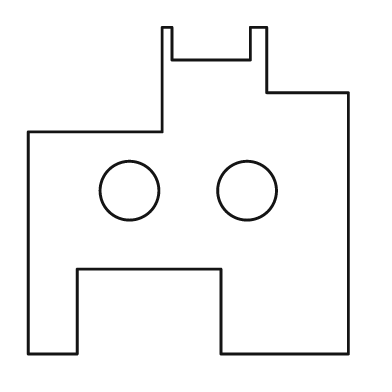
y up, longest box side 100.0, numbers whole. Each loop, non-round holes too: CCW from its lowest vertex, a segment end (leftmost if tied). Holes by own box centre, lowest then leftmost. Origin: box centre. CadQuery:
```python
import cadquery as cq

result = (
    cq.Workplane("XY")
    .moveTo(-49.0, -50.0)
    .lineTo(-34.0, -50.0)
    .lineTo(-34.0, -24.0)
    .lineTo(10.0, -24.0)
    .lineTo(10.0, -50.0)
    .lineTo(49.0, -50.0)
    .lineTo(49.0, 30.0)
    .lineTo(24.0, 30.0)
    .lineTo(24.0, 50.0)
    .lineTo(19.0, 50.0)
    .lineTo(19.0, 40.0)
    .lineTo(-5.0, 40.0)
    .lineTo(-5.0, 50.0)
    .lineTo(-8.0, 50.0)
    .lineTo(-8.0, 18.0)
    .lineTo(-49.0, 18.0)
    .close()
    .moveTo(-18.0, 0.0)
    .circle(9.0)
    .moveTo(18.0, 0.0)
    .circle(9.0)
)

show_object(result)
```